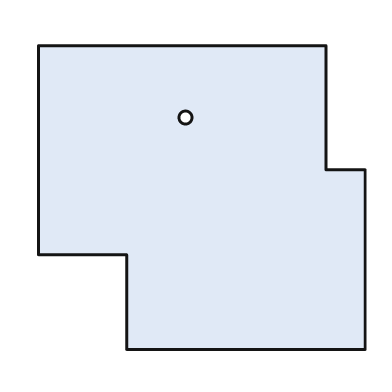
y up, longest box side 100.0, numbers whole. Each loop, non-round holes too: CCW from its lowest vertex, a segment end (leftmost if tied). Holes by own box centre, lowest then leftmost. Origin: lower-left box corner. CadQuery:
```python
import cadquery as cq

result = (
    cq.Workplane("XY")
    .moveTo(27.0, 0.0)
    .lineTo(100.0, 0.0)
    .lineTo(100.0, 55.0)
    .lineTo(88.0, 55.0)
    .lineTo(88.0, 93.0)
    .lineTo(0.0, 93.0)
    .lineTo(0.0, 29.0)
    .lineTo(27.0, 29.0)
    .close()
    .moveTo(45.0, 71.0)
    .circle(2.0)
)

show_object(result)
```